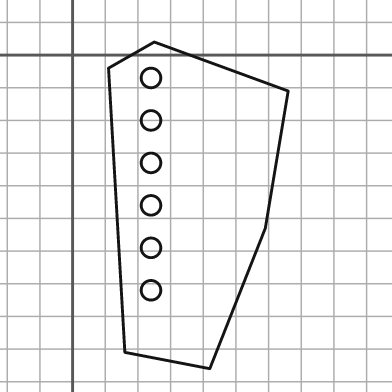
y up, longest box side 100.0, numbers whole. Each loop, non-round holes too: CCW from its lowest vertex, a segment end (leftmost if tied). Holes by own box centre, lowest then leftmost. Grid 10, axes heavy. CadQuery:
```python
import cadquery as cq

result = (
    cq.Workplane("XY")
    .moveTo(42.0, -96.0)
    .lineTo(59.0, -53.0)
    .lineTo(66.0, -11.0)
    .lineTo(25.0, 4.0)
    .lineTo(11.0, -4.0)
    .lineTo(16.0, -91.0)
    .close()
    .moveTo(24.0, -72.0)
    .circle(3.0)
    .moveTo(24.0, -59.0)
    .circle(3.0)
    .moveTo(24.0, -46.0)
    .circle(3.0)
    .moveTo(24.0, -33.0)
    .circle(3.0)
    .moveTo(24.0, -20.0)
    .circle(3.0)
    .moveTo(24.0, -7.0)
    .circle(3.0)
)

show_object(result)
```